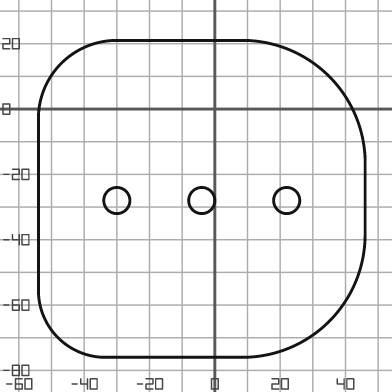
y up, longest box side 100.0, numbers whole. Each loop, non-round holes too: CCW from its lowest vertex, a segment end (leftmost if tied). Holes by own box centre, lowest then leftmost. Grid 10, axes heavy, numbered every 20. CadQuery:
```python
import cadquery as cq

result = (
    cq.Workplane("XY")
    .moveTo(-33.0, -76.0)
    .lineTo(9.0, -76.0)
    .threePointArc((35.0, -65.0), (46.0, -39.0))
    .lineTo(46.0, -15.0)
    .threePointArc((35.0, 10.0), (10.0, 21.0))
    .lineTo(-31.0, 21.0)
    .threePointArc((-47.0, 14.0), (-54.0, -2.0))
    .lineTo(-54.0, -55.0)
    .threePointArc((-48.0, -70.0), (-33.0, -76.0))
    .close()
    .moveTo(-30.0, -28.0)
    .circle(4.0)
    .moveTo(-4.0, -28.0)
    .circle(4.0)
    .moveTo(22.0, -28.0)
    .circle(4.0)
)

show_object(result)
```